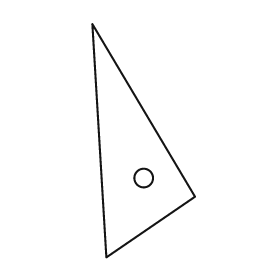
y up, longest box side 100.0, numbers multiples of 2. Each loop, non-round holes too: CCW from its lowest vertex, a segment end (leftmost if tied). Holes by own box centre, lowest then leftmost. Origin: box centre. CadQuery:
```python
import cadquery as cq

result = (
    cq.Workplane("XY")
    .moveTo(-16.0, -50.0)
    .lineTo(22.0, -24.0)
    .lineTo(-22.0, 50.0)
    .close()
    .moveTo(0.0, -16.0)
    .circle(4.0)
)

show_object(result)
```